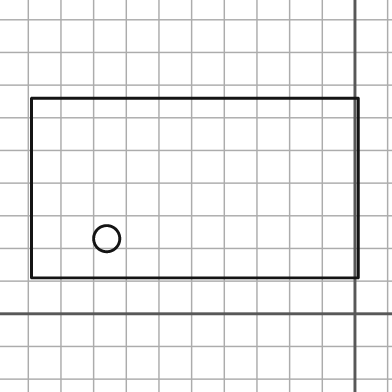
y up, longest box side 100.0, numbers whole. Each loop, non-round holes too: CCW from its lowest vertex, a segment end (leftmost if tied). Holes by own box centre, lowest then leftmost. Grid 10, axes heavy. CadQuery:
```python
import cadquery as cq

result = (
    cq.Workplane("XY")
    .moveTo(-99.0, 11.0)
    .lineTo(1.0, 11.0)
    .lineTo(1.0, 66.0)
    .lineTo(-99.0, 66.0)
    .close()
    .moveTo(-76.0, 23.0)
    .circle(4.0)
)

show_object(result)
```